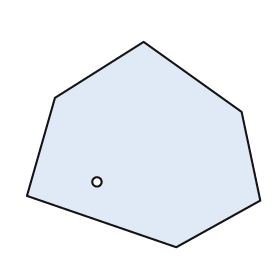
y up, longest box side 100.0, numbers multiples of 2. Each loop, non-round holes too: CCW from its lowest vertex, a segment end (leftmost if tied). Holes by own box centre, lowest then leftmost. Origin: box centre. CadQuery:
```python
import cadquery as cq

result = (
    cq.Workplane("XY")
    .moveTo(14.0, -44.0)
    .lineTo(50.0, -24.0)
    .lineTo(42.0, 14.0)
    .lineTo(0.0, 44.0)
    .lineTo(-38.0, 20.0)
    .lineTo(-50.0, -22.0)
    .close()
    .moveTo(-20.0, -16.0)
    .circle(2.0)
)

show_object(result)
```